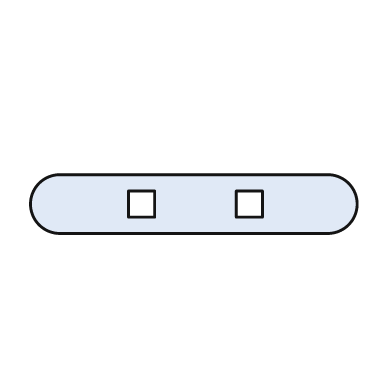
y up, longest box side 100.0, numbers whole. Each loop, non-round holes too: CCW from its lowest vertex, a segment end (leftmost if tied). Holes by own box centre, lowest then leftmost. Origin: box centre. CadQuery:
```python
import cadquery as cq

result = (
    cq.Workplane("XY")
    .moveTo(-41.0, -9.0)
    .lineTo(41.0, -9.0)
    .threePointArc((50.0, 0.0), (41.0, 9.0))
    .lineTo(-41.0, 9.0)
    .threePointArc((-50.0, 0.0), (-41.0, -9.0))
    .close()
    .moveTo(-20.0, -4.0)
    .lineTo(-12.0, -4.0)
    .lineTo(-12.0, 4.0)
    .lineTo(-20.0, 4.0)
    .close()
    .moveTo(13.0, -4.0)
    .lineTo(21.0, -4.0)
    .lineTo(21.0, 4.0)
    .lineTo(13.0, 4.0)
    .close()
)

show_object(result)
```